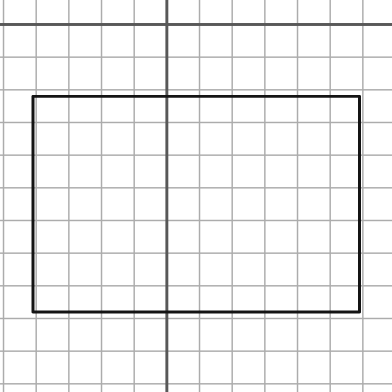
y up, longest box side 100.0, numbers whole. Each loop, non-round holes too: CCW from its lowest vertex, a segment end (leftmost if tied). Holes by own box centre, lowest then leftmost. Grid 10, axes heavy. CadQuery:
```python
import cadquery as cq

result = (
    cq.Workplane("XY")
    .moveTo(-41.0, -88.0)
    .lineTo(59.0, -88.0)
    .lineTo(59.0, -22.0)
    .lineTo(-41.0, -22.0)
    .close()
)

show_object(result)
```